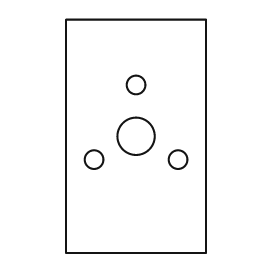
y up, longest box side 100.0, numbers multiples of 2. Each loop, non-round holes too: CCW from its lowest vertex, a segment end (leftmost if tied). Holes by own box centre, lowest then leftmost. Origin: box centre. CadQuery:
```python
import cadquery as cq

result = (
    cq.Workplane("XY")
    .moveTo(-30.0, -50.0)
    .lineTo(30.0, -50.0)
    .lineTo(30.0, 50.0)
    .lineTo(-30.0, 50.0)
    .close()
    .moveTo(-18.0, -10.0)
    .circle(4.0)
    .moveTo(18.0, -10.0)
    .circle(4.0)
    .moveTo(0.0, 0.0)
    .circle(8.0)
    .moveTo(0.0, 22.0)
    .circle(4.0)
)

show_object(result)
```